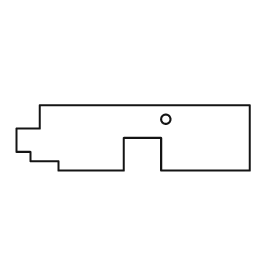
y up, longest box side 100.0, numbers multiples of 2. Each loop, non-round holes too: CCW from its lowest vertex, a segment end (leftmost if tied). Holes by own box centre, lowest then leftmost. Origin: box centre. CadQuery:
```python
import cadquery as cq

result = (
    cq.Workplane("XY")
    .moveTo(-32.0, -14.0)
    .lineTo(-4.0, -14.0)
    .lineTo(-4.0, 0.0)
    .lineTo(12.0, 0.0)
    .lineTo(12.0, -14.0)
    .lineTo(50.0, -14.0)
    .lineTo(50.0, 14.0)
    .lineTo(-40.0, 14.0)
    .lineTo(-40.0, 4.0)
    .lineTo(-50.0, 4.0)
    .lineTo(-50.0, -6.0)
    .lineTo(-44.0, -6.0)
    .lineTo(-44.0, -10.0)
    .lineTo(-32.0, -10.0)
    .close()
    .moveTo(14.0, 8.0)
    .circle(2.0)
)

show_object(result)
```